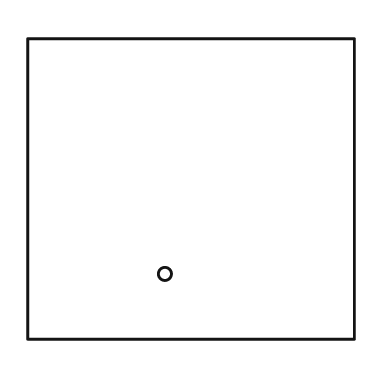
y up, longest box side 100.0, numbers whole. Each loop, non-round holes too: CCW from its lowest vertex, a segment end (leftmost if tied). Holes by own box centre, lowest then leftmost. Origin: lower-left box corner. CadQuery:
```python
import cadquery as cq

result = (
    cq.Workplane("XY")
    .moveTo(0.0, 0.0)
    .lineTo(100.0, 0.0)
    .lineTo(100.0, 92.0)
    .lineTo(0.0, 92.0)
    .close()
    .moveTo(42.0, 20.0)
    .circle(2.0)
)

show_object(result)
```